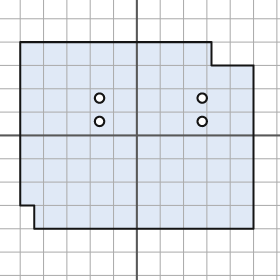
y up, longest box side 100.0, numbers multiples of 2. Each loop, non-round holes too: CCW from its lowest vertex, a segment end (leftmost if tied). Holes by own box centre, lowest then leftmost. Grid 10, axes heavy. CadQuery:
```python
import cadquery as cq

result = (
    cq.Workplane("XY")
    .moveTo(-44.0, -40.0)
    .lineTo(50.0, -40.0)
    .lineTo(50.0, 30.0)
    .lineTo(32.0, 30.0)
    .lineTo(32.0, 40.0)
    .lineTo(-50.0, 40.0)
    .lineTo(-50.0, -30.0)
    .lineTo(-44.0, -30.0)
    .close()
    .moveTo(-16.0, 6.0)
    .circle(2.0)
    .moveTo(28.0, 6.0)
    .circle(2.0)
    .moveTo(-16.0, 16.0)
    .circle(2.0)
    .moveTo(28.0, 16.0)
    .circle(2.0)
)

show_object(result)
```